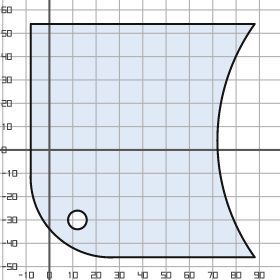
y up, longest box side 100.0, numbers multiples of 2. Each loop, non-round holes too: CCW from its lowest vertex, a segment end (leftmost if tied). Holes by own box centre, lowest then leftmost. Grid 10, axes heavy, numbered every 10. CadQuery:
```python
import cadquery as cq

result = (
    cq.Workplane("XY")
    .moveTo(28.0, -46.0)
    .lineTo(88.0, -46.0)
    .threePointArc((72.0, 4.0), (88.0, 54.0))
    .lineTo(-8.0, 54.0)
    .lineTo(-8.0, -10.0)
    .threePointArc((2.0, -36.0), (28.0, -46.0))
    .close()
    .moveTo(12.0, -30.0)
    .circle(4.0)
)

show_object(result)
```